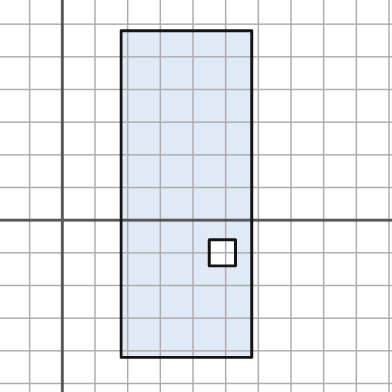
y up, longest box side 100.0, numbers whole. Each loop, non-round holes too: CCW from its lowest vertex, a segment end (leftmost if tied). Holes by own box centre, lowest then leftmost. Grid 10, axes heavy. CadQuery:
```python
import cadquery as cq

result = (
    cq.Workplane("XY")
    .moveTo(18.0, -42.0)
    .lineTo(58.0, -42.0)
    .lineTo(58.0, 58.0)
    .lineTo(18.0, 58.0)
    .close()
    .moveTo(45.0, -14.0)
    .lineTo(53.0, -14.0)
    .lineTo(53.0, -6.0)
    .lineTo(45.0, -6.0)
    .close()
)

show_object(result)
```